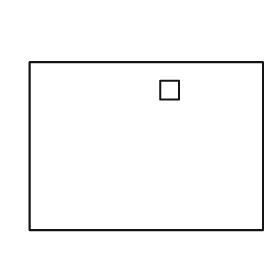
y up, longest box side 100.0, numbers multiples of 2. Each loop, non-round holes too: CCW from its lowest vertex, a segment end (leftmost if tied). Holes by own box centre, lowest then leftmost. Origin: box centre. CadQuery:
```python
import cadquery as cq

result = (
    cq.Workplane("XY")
    .moveTo(-50.0, -36.0)
    .lineTo(50.0, -36.0)
    .lineTo(50.0, 36.0)
    .lineTo(-50.0, 36.0)
    .close()
    .moveTo(6.0, 20.0)
    .lineTo(14.0, 20.0)
    .lineTo(14.0, 28.0)
    .lineTo(6.0, 28.0)
    .close()
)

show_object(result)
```